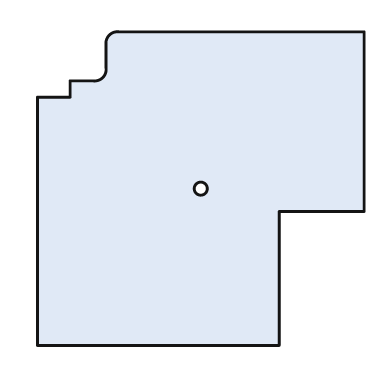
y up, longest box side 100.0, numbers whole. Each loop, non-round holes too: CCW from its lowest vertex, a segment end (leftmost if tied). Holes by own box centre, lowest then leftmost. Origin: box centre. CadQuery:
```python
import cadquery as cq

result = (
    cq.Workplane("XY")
    .moveTo(-50.0, -48.0)
    .lineTo(24.0, -48.0)
    .lineTo(24.0, -7.0)
    .lineTo(50.0, -7.0)
    .lineTo(50.0, 48.0)
    .lineTo(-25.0, 48.0)
    .threePointArc((-28.0, 47.0), (-29.0, 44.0))
    .lineTo(-29.0, 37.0)
    .threePointArc((-30.0, 34.0), (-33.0, 33.0))
    .lineTo(-40.0, 33.0)
    .lineTo(-40.0, 28.0)
    .lineTo(-50.0, 28.0)
    .close()
    .moveTo(0.0, 0.0)
    .circle(2.0)
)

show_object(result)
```